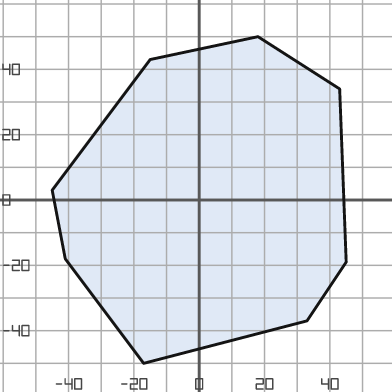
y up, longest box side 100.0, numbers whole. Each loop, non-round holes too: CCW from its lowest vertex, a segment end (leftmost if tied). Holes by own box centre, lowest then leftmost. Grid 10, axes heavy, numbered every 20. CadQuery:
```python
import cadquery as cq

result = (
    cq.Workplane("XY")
    .moveTo(-17.0, -50.0)
    .lineTo(33.0, -37.0)
    .lineTo(45.0, -19.0)
    .lineTo(43.0, 34.0)
    .lineTo(18.0, 50.0)
    .lineTo(-15.0, 43.0)
    .lineTo(-45.0, 3.0)
    .lineTo(-41.0, -18.0)
    .close()
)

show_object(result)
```